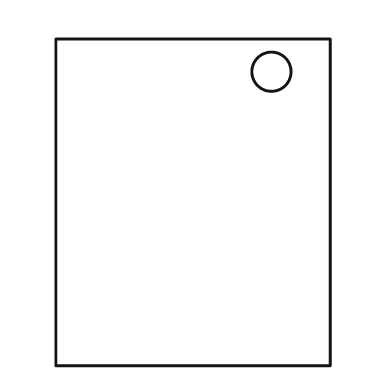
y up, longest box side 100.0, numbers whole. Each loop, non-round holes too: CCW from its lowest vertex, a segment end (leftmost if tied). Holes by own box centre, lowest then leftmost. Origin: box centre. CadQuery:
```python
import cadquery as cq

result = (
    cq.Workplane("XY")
    .moveTo(-42.0, -50.0)
    .lineTo(42.0, -50.0)
    .lineTo(42.0, 50.0)
    .lineTo(-42.0, 50.0)
    .close()
    .moveTo(24.0, 40.0)
    .circle(6.0)
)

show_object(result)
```